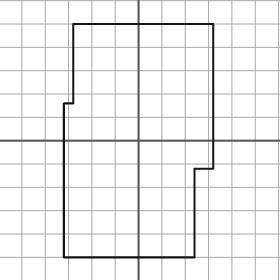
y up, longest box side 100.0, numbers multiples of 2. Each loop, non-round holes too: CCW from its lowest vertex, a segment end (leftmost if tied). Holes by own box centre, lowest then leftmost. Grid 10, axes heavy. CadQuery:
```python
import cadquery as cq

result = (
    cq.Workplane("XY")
    .moveTo(-32.0, -50.0)
    .lineTo(24.0, -50.0)
    .lineTo(24.0, -12.0)
    .lineTo(32.0, -12.0)
    .lineTo(32.0, 50.0)
    .lineTo(-28.0, 50.0)
    .lineTo(-28.0, 16.0)
    .lineTo(-32.0, 16.0)
    .close()
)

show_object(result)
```